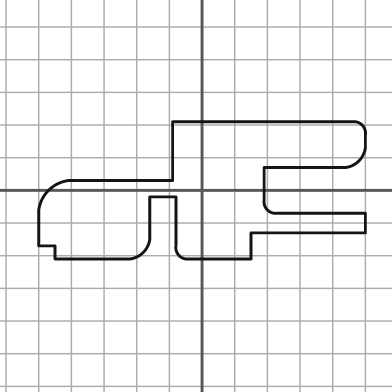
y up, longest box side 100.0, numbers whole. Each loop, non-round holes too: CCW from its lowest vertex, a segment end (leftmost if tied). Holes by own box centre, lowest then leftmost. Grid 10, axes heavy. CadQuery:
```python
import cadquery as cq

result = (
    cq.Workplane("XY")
    .moveTo(-45.0, -21.0)
    .lineTo(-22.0, -21.0)
    .threePointArc((-18.0, -19.0), (-16.0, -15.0))
    .lineTo(-16.0, -2.0)
    .lineTo(-8.0, -2.0)
    .lineTo(-8.0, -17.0)
    .threePointArc((-7.0, -20.0), (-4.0, -21.0))
    .lineTo(15.0, -21.0)
    .lineTo(15.0, -13.0)
    .lineTo(50.0, -13.0)
    .lineTo(50.0, -7.0)
    .lineTo(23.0, -7.0)
    .threePointArc((20.0, -6.0), (19.0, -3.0))
    .lineTo(19.0, 7.0)
    .lineTo(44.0, 7.0)
    .threePointArc((48.0, 9.0), (50.0, 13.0))
    .lineTo(50.0, 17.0)
    .threePointArc((49.0, 20.0), (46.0, 21.0))
    .lineTo(-9.0, 21.0)
    .lineTo(-9.0, 3.0)
    .lineTo(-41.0, 3.0)
    .threePointArc((-47.0, 0.0), (-50.0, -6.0))
    .lineTo(-50.0, -17.0)
    .lineTo(-45.0, -17.0)
    .close()
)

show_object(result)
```